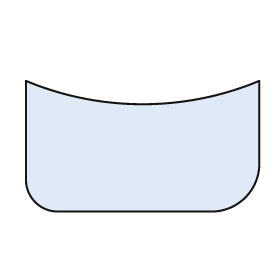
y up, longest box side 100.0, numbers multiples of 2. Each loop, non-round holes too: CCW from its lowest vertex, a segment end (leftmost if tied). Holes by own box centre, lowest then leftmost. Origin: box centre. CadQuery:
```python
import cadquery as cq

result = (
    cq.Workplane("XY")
    .moveTo(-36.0, -28.0)
    .lineTo(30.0, -28.0)
    .threePointArc((44.0, -22.0), (50.0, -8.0))
    .lineTo(50.0, 28.0)
    .threePointArc((0.0, 18.0), (-50.0, 28.0))
    .lineTo(-50.0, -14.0)
    .threePointArc((-46.0, -24.0), (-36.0, -28.0))
    .close()
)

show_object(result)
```